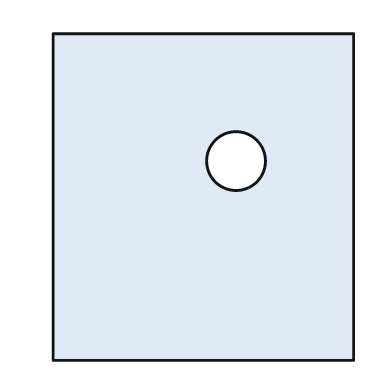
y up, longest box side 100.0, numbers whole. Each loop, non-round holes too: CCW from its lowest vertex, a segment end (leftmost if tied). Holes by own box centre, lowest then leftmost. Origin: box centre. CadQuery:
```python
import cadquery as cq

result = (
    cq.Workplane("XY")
    .moveTo(-46.0, -50.0)
    .lineTo(46.0, -50.0)
    .lineTo(46.0, 50.0)
    .lineTo(-46.0, 50.0)
    .close()
    .moveTo(10.0, 11.0)
    .circle(9.0)
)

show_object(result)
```